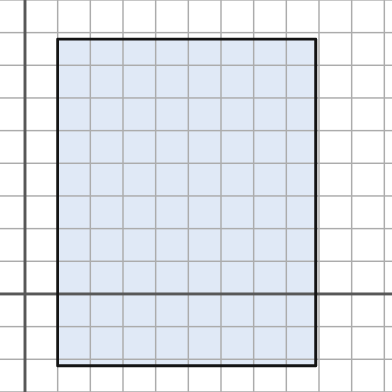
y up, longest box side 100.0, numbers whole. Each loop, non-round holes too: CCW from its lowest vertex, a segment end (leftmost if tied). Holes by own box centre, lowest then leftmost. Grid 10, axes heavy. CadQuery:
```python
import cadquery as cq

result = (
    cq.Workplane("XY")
    .moveTo(10.0, -22.0)
    .lineTo(89.0, -22.0)
    .lineTo(89.0, 78.0)
    .lineTo(10.0, 78.0)
    .close()
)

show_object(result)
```